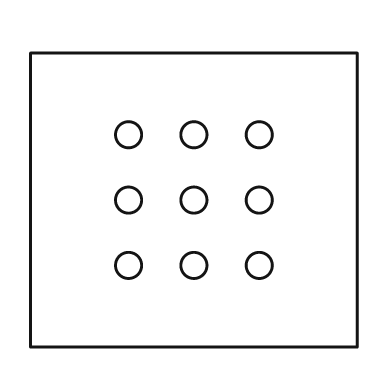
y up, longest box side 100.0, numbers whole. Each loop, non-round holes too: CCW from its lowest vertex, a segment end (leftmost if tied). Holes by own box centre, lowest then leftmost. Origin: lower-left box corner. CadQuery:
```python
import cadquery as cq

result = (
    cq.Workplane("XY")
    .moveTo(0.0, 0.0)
    .lineTo(100.0, 0.0)
    .lineTo(100.0, 90.0)
    .lineTo(0.0, 90.0)
    .close()
    .moveTo(30.0, 25.0)
    .circle(4.0)
    .moveTo(50.0, 25.0)
    .circle(4.0)
    .moveTo(70.0, 25.0)
    .circle(4.0)
    .moveTo(30.0, 45.0)
    .circle(4.0)
    .moveTo(50.0, 45.0)
    .circle(4.0)
    .moveTo(70.0, 45.0)
    .circle(4.0)
    .moveTo(30.0, 65.0)
    .circle(4.0)
    .moveTo(50.0, 65.0)
    .circle(4.0)
    .moveTo(70.0, 65.0)
    .circle(4.0)
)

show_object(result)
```